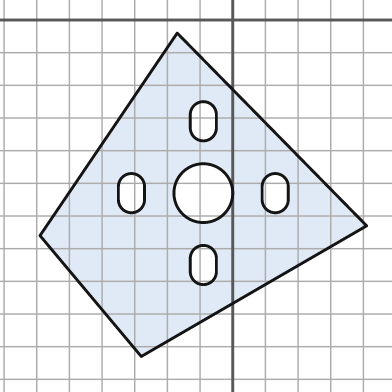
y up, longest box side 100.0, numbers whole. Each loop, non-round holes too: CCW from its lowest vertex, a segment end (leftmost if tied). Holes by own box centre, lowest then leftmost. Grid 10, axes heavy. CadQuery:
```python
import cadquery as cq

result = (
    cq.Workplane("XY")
    .moveTo(-28.0, -103.0)
    .lineTo(41.0, -63.0)
    .lineTo(-17.0, -4.0)
    .lineTo(-59.0, -66.0)
    .close()
    .moveTo(-13.0, -77.0)
    .threePointArc((-9.0, -81.0), (-5.0, -77.0))
    .lineTo(-5.0, -73.0)
    .threePointArc((-9.0, -69.0), (-13.0, -73.0))
    .close()
    .moveTo(-35.0, -55.0)
    .threePointArc((-31.0, -59.0), (-27.0, -55.0))
    .lineTo(-27.0, -51.0)
    .threePointArc((-31.0, -47.0), (-35.0, -51.0))
    .close()
    .moveTo(-9.0, -53.0)
    .circle(9.0)
    .moveTo(9.0, -55.0)
    .threePointArc((13.0, -59.0), (17.0, -55.0))
    .lineTo(17.0, -51.0)
    .threePointArc((13.0, -47.0), (9.0, -51.0))
    .close()
    .moveTo(-13.0, -33.0)
    .threePointArc((-9.0, -37.0), (-5.0, -33.0))
    .lineTo(-5.0, -29.0)
    .threePointArc((-9.0, -25.0), (-13.0, -29.0))
    .close()
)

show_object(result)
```